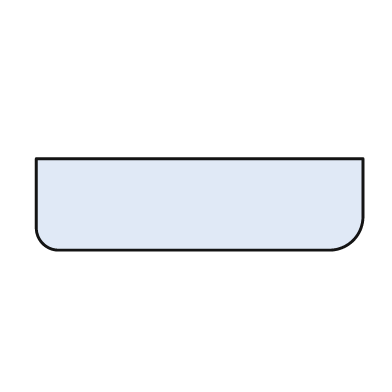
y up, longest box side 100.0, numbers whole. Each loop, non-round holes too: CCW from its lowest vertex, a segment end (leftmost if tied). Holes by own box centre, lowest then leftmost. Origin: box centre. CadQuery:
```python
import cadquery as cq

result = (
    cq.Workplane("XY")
    .moveTo(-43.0, -14.0)
    .lineTo(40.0, -14.0)
    .threePointArc((47.0, -11.0), (50.0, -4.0))
    .lineTo(50.0, 14.0)
    .lineTo(-50.0, 14.0)
    .lineTo(-50.0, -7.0)
    .threePointArc((-48.0, -12.0), (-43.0, -14.0))
    .close()
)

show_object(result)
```